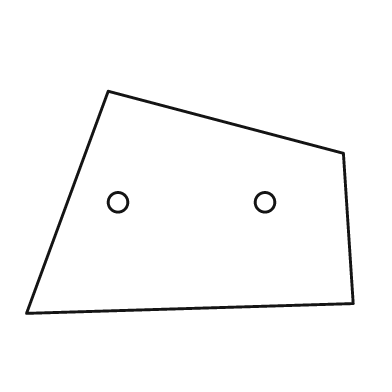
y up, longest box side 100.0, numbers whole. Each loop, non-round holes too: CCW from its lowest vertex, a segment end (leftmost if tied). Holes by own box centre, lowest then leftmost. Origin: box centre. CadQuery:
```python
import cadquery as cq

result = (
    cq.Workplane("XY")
    .moveTo(-50.0, -34.0)
    .lineTo(50.0, -31.0)
    .lineTo(47.0, 15.0)
    .lineTo(-25.0, 34.0)
    .close()
    .moveTo(-22.0, 0.0)
    .circle(3.0)
    .moveTo(23.0, 0.0)
    .circle(3.0)
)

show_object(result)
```